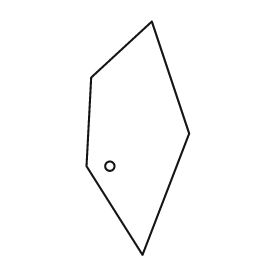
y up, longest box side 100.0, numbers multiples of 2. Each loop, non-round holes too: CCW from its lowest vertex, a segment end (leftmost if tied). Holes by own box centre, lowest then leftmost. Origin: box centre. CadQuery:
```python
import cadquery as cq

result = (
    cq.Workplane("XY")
    .moveTo(2.0, -50.0)
    .lineTo(22.0, 2.0)
    .lineTo(6.0, 50.0)
    .lineTo(-20.0, 26.0)
    .lineTo(-22.0, -12.0)
    .close()
    .moveTo(-12.0, -12.0)
    .circle(2.0)
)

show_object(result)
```